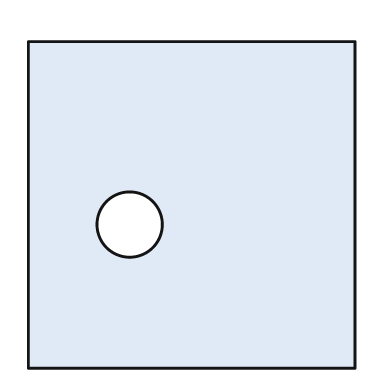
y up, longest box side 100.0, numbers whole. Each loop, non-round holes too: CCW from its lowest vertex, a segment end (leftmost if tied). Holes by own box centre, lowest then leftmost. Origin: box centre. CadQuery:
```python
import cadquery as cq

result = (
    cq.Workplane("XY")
    .moveTo(-50.0, -50.0)
    .lineTo(50.0, -50.0)
    .lineTo(50.0, 50.0)
    .lineTo(-50.0, 50.0)
    .close()
    .moveTo(-19.0, -6.0)
    .circle(10.0)
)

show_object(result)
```